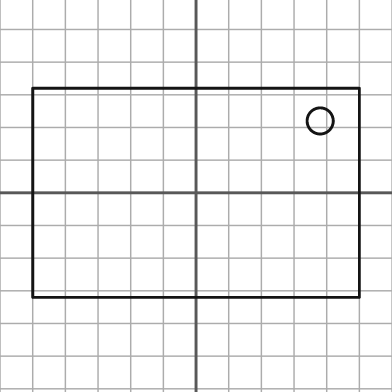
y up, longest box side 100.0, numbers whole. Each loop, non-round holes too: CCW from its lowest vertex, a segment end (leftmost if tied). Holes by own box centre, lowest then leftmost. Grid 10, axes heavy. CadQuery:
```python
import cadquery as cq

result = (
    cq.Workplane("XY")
    .moveTo(-50.0, -32.0)
    .lineTo(50.0, -32.0)
    .lineTo(50.0, 32.0)
    .lineTo(-50.0, 32.0)
    .close()
    .moveTo(38.0, 22.0)
    .circle(4.0)
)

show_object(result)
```